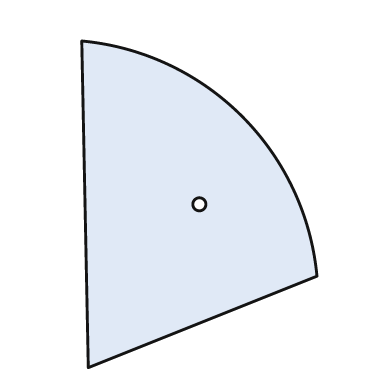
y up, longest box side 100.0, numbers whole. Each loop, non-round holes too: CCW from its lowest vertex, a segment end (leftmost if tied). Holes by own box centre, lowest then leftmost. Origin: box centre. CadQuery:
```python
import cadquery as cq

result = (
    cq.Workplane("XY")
    .moveTo(-34.0, -50.0)
    .lineTo(36.0, -22.0)
    .threePointArc((13.0, 27.0), (-36.0, 50.0))
    .close()
    .moveTo(0.0, 0.0)
    .circle(2.0)
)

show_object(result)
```